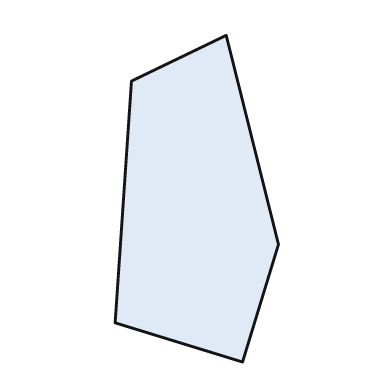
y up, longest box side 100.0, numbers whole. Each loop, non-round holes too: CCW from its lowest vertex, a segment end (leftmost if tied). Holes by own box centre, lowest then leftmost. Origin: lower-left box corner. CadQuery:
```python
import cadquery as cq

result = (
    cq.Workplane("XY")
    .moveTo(39.0, 0.0)
    .lineTo(50.0, 36.0)
    .lineTo(34.0, 100.0)
    .lineTo(5.0, 86.0)
    .lineTo(0.0, 12.0)
    .close()
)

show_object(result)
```